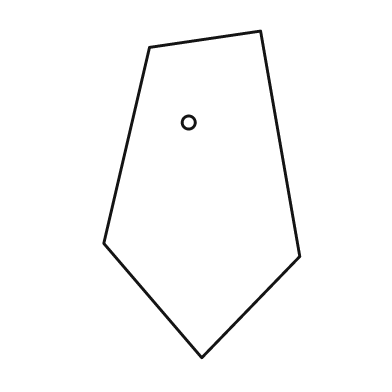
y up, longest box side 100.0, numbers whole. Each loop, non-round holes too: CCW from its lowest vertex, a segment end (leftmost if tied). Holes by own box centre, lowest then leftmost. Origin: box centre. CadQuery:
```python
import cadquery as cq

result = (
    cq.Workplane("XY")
    .moveTo(0.0, -50.0)
    .lineTo(30.0, -19.0)
    .lineTo(18.0, 50.0)
    .lineTo(-16.0, 45.0)
    .lineTo(-30.0, -15.0)
    .close()
    .moveTo(-4.0, 22.0)
    .circle(2.0)
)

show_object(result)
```